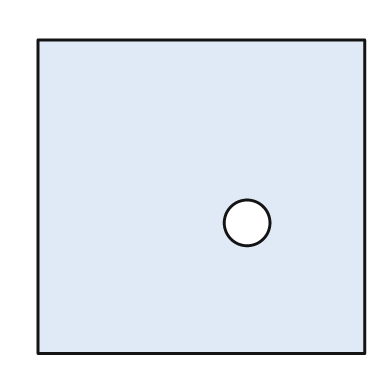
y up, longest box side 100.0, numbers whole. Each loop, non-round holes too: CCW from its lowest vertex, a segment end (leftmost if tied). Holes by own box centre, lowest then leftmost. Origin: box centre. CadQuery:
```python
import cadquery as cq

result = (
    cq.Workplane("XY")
    .moveTo(-50.0, -48.0)
    .lineTo(50.0, -48.0)
    .lineTo(50.0, 48.0)
    .lineTo(-50.0, 48.0)
    .close()
    .moveTo(14.0, -8.0)
    .circle(7.0)
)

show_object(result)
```